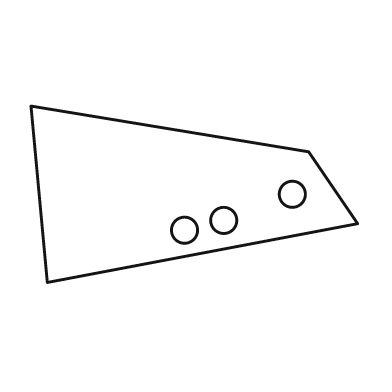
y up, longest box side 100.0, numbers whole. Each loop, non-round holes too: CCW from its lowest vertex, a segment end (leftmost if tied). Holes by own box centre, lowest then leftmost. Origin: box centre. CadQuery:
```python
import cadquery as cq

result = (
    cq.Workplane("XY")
    .moveTo(-45.0, -27.0)
    .lineTo(50.0, -9.0)
    .lineTo(35.0, 13.0)
    .lineTo(-50.0, 27.0)
    .close()
    .moveTo(-3.0, -11.0)
    .circle(4.0)
    .moveTo(9.0, -8.0)
    .circle(4.0)
    .moveTo(30.0, 0.0)
    .circle(4.0)
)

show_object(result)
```